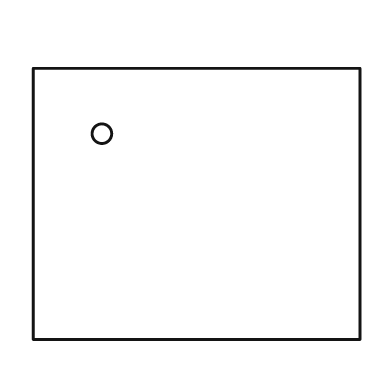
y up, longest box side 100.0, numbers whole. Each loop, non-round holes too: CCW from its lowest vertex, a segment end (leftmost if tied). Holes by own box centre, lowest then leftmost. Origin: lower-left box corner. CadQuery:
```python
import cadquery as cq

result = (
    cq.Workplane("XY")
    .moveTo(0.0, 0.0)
    .lineTo(100.0, 0.0)
    .lineTo(100.0, 83.0)
    .lineTo(0.0, 83.0)
    .close()
    .moveTo(21.0, 63.0)
    .circle(3.0)
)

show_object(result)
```